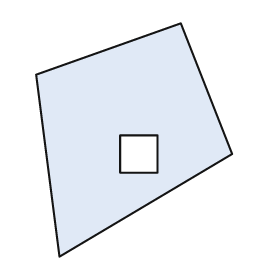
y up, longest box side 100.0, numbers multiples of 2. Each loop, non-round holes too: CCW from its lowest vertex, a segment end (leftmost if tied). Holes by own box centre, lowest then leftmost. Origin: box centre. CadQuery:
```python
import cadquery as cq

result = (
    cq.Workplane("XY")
    .moveTo(-32.0, -50.0)
    .lineTo(42.0, -6.0)
    .lineTo(20.0, 50.0)
    .lineTo(-42.0, 28.0)
    .close()
    .moveTo(-6.0, -14.0)
    .lineTo(10.0, -14.0)
    .lineTo(10.0, 2.0)
    .lineTo(-6.0, 2.0)
    .close()
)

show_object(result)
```